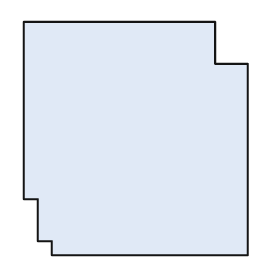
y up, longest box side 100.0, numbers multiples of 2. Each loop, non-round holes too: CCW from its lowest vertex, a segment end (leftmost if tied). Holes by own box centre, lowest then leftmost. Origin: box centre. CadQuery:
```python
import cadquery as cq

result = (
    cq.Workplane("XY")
    .moveTo(-36.0, -50.0)
    .lineTo(48.0, -50.0)
    .lineTo(48.0, 32.0)
    .lineTo(34.0, 32.0)
    .lineTo(34.0, 50.0)
    .lineTo(-48.0, 50.0)
    .lineTo(-48.0, -26.0)
    .lineTo(-42.0, -26.0)
    .lineTo(-42.0, -44.0)
    .lineTo(-36.0, -44.0)
    .close()
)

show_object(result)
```